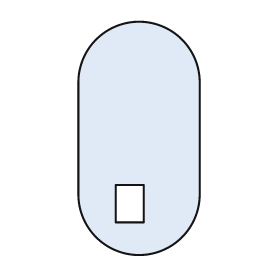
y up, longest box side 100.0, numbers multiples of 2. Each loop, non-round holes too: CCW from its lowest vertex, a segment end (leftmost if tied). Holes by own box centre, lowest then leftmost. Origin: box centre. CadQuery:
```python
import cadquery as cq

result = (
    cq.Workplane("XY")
    .moveTo(-26.0, -24.0)
    .threePointArc((0.0, -50.0), (26.0, -24.0))
    .lineTo(26.0, 24.0)
    .threePointArc((0.0, 50.0), (-26.0, 24.0))
    .close()
    .moveTo(-10.0, -36.0)
    .lineTo(2.0, -36.0)
    .lineTo(2.0, -20.0)
    .lineTo(-10.0, -20.0)
    .close()
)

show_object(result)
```